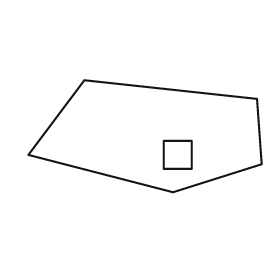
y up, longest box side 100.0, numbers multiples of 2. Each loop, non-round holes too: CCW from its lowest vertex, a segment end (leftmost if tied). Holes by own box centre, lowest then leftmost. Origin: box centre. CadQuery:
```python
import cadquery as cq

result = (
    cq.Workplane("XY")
    .moveTo(12.0, -24.0)
    .lineTo(50.0, -12.0)
    .lineTo(48.0, 16.0)
    .lineTo(-26.0, 24.0)
    .lineTo(-50.0, -8.0)
    .close()
    .moveTo(8.0, -14.0)
    .lineTo(20.0, -14.0)
    .lineTo(20.0, -2.0)
    .lineTo(8.0, -2.0)
    .close()
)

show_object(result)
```